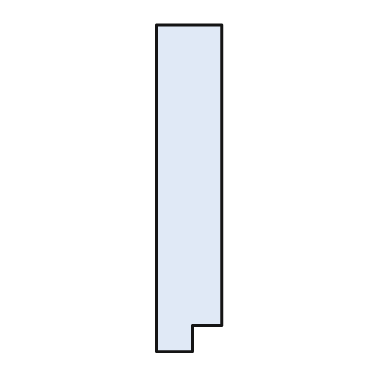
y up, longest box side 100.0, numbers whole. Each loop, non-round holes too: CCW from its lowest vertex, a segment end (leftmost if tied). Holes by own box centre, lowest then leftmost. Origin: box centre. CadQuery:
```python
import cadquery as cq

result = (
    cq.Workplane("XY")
    .moveTo(-10.0, -50.0)
    .lineTo(1.0, -50.0)
    .lineTo(1.0, -42.0)
    .lineTo(10.0, -42.0)
    .lineTo(10.0, 50.0)
    .lineTo(-10.0, 50.0)
    .close()
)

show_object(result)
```